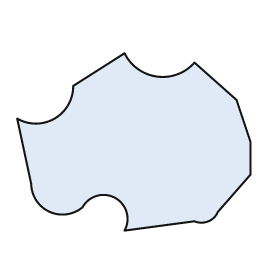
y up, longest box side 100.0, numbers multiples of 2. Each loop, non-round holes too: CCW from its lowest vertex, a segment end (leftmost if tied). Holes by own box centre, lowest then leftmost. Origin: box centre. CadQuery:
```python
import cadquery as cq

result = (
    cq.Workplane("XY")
    .moveTo(-4.0, -38.0)
    .lineTo(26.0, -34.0)
    .threePointArc((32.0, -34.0), (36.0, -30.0))
    .lineTo(50.0, -14.0)
    .lineTo(50.0, 0.0)
    .lineTo(44.0, 18.0)
    .lineTo(26.0, 34.0)
    .threePointArc((10.0, 28.0), (-4.0, 38.0))
    .lineTo(-26.0, 24.0)
    .threePointArc((-34.0, 10.0), (-50.0, 10.0))
    .lineTo(-44.0, -18.0)
    .threePointArc((-36.0, -30.0), (-22.0, -28.0))
    .threePointArc((-8.0, -24.0), (-4.0, -38.0))
    .close()
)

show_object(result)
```